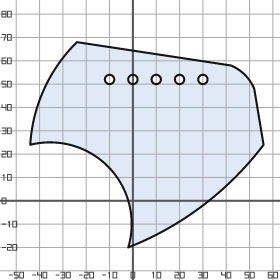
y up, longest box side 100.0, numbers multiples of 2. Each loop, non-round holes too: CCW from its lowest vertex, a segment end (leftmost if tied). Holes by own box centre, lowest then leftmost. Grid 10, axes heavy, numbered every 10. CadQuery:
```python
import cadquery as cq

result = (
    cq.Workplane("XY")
    .moveTo(-2.0, -20.0)
    .threePointArc((30.0, -2.0), (56.0, 24.0))
    .lineTo(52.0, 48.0)
    .threePointArc((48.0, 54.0), (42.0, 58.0))
    .lineTo(-24.0, 68.0)
    .threePointArc((-38.0, 48.0), (-44.0, 24.0))
    .threePointArc((-10.0, 14.0), (-2.0, -20.0))
    .close()
    .moveTo(-10.0, 52.0)
    .circle(2.0)
    .moveTo(0.0, 52.0)
    .circle(2.0)
    .moveTo(10.0, 52.0)
    .circle(2.0)
    .moveTo(20.0, 52.0)
    .circle(2.0)
    .moveTo(30.0, 52.0)
    .circle(2.0)
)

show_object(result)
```